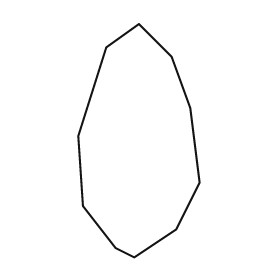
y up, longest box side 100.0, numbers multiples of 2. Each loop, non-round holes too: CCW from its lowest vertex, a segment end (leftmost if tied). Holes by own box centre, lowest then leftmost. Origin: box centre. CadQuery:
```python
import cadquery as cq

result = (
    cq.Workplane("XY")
    .moveTo(-2.0, -50.0)
    .lineTo(16.0, -38.0)
    .lineTo(26.0, -18.0)
    .lineTo(22.0, 14.0)
    .lineTo(14.0, 36.0)
    .lineTo(0.0, 50.0)
    .lineTo(-14.0, 40.0)
    .lineTo(-26.0, 2.0)
    .lineTo(-24.0, -28.0)
    .lineTo(-10.0, -46.0)
    .close()
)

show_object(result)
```